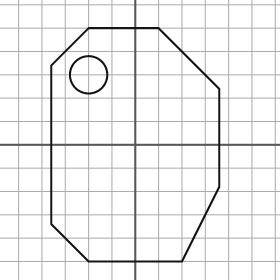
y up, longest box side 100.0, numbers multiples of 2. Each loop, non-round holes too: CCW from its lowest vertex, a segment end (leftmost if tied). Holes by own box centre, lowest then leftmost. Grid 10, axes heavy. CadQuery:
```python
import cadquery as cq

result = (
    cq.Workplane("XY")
    .moveTo(-20.0, -50.0)
    .lineTo(20.0, -50.0)
    .lineTo(36.0, -18.0)
    .lineTo(36.0, 24.0)
    .lineTo(10.0, 50.0)
    .lineTo(-20.0, 50.0)
    .lineTo(-36.0, 34.0)
    .lineTo(-36.0, -34.0)
    .close()
    .moveTo(-20.0, 30.0)
    .circle(8.0)
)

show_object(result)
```